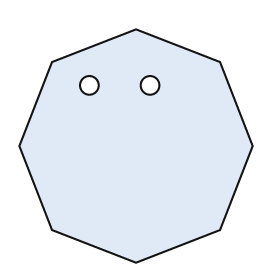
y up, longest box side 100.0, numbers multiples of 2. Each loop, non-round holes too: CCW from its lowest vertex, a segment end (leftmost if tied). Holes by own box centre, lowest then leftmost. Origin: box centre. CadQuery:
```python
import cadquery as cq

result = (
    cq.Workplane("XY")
    .moveTo(0.0, -50.0)
    .lineTo(36.0, -36.0)
    .lineTo(50.0, 0.0)
    .lineTo(36.0, 36.0)
    .lineTo(0.0, 50.0)
    .lineTo(-36.0, 36.0)
    .lineTo(-50.0, 0.0)
    .lineTo(-36.0, -36.0)
    .close()
    .moveTo(-20.0, 26.0)
    .circle(4.0)
    .moveTo(6.0, 26.0)
    .circle(4.0)
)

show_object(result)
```